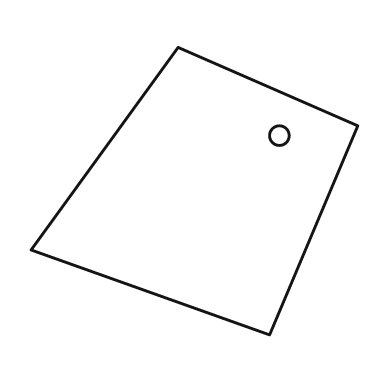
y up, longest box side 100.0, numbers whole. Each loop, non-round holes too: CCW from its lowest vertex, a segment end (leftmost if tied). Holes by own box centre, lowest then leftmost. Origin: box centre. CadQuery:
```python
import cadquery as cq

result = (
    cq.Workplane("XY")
    .moveTo(23.0, -44.0)
    .lineTo(50.0, 20.0)
    .lineTo(-5.0, 44.0)
    .lineTo(-50.0, -18.0)
    .close()
    .moveTo(26.0, 17.0)
    .circle(3.0)
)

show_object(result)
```